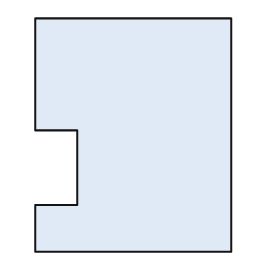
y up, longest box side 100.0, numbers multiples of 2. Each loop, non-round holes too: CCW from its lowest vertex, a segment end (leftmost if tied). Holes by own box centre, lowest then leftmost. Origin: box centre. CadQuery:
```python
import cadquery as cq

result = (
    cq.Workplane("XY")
    .moveTo(-42.0, -50.0)
    .lineTo(42.0, -50.0)
    .lineTo(42.0, 50.0)
    .lineTo(-42.0, 50.0)
    .lineTo(-42.0, 2.0)
    .lineTo(-24.0, 2.0)
    .lineTo(-24.0, -30.0)
    .lineTo(-42.0, -30.0)
    .close()
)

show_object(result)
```